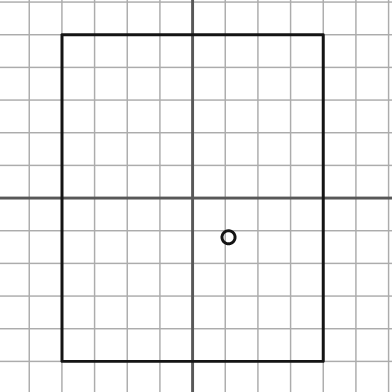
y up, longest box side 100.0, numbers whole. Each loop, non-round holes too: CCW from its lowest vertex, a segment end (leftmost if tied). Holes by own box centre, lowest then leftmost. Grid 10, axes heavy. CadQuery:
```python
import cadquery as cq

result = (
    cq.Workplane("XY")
    .moveTo(-40.0, -50.0)
    .lineTo(40.0, -50.0)
    .lineTo(40.0, 50.0)
    .lineTo(-40.0, 50.0)
    .close()
    .moveTo(11.0, -12.0)
    .circle(2.0)
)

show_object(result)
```